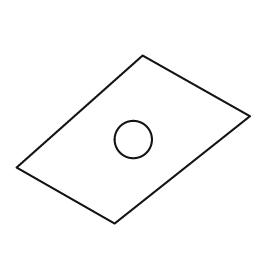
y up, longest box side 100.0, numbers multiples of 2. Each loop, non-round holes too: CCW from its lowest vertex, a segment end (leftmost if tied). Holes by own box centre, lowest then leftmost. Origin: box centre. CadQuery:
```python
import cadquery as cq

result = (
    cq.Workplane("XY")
    .moveTo(-8.0, -36.0)
    .lineTo(50.0, 10.0)
    .lineTo(4.0, 36.0)
    .lineTo(-50.0, -12.0)
    .close()
    .moveTo(0.0, 0.0)
    .circle(8.0)
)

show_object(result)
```